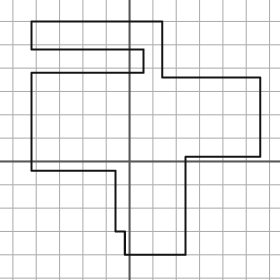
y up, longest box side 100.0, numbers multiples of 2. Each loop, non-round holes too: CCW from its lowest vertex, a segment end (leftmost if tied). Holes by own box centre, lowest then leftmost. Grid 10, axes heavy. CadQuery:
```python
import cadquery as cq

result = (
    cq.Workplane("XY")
    .moveTo(-2.0, -40.0)
    .lineTo(24.0, -40.0)
    .lineTo(24.0, 2.0)
    .lineTo(56.0, 2.0)
    .lineTo(56.0, 36.0)
    .lineTo(14.0, 36.0)
    .lineTo(14.0, 60.0)
    .lineTo(-42.0, 60.0)
    .lineTo(-42.0, 48.0)
    .lineTo(6.0, 48.0)
    .lineTo(6.0, 38.0)
    .lineTo(-42.0, 38.0)
    .lineTo(-42.0, -4.0)
    .lineTo(-6.0, -4.0)
    .lineTo(-6.0, -30.0)
    .lineTo(-2.0, -30.0)
    .close()
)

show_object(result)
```